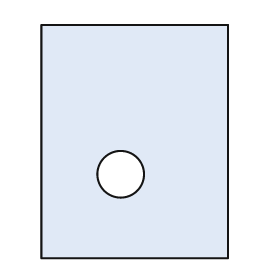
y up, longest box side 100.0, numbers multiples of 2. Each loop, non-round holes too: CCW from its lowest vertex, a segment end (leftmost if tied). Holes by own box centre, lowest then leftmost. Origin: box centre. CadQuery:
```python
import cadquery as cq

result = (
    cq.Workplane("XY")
    .moveTo(-40.0, -50.0)
    .lineTo(40.0, -50.0)
    .lineTo(40.0, 50.0)
    .lineTo(-40.0, 50.0)
    .close()
    .moveTo(-6.0, -14.0)
    .circle(10.0)
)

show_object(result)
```